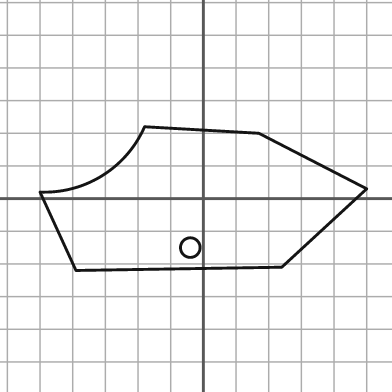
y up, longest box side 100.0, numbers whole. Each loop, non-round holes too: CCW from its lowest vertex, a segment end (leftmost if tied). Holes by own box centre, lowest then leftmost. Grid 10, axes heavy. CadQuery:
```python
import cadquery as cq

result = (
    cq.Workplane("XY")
    .moveTo(-39.0, -22.0)
    .lineTo(24.0, -21.0)
    .lineTo(50.0, 3.0)
    .lineTo(17.0, 20.0)
    .lineTo(-18.0, 22.0)
    .threePointArc((-31.0, 7.0), (-50.0, 2.0))
    .close()
    .moveTo(-4.0, -15.0)
    .circle(3.0)
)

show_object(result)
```